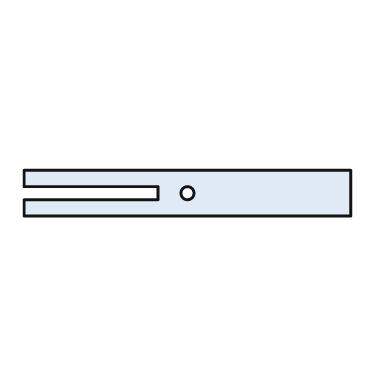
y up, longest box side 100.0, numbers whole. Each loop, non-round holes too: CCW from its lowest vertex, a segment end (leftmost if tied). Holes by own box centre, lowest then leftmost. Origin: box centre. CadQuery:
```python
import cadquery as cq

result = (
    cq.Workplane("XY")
    .moveTo(-50.0, -7.0)
    .lineTo(50.0, -7.0)
    .lineTo(50.0, 7.0)
    .lineTo(-50.0, 7.0)
    .lineTo(-50.0, 2.0)
    .lineTo(-9.0, 2.0)
    .lineTo(-9.0, -2.0)
    .lineTo(-50.0, -2.0)
    .close()
    .moveTo(0.0, 0.0)
    .circle(2.0)
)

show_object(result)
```